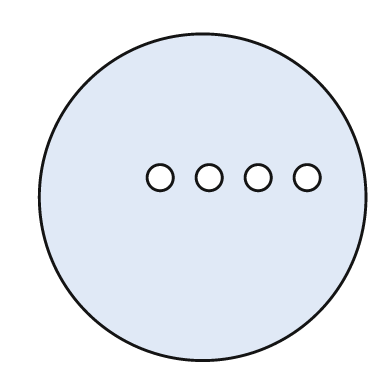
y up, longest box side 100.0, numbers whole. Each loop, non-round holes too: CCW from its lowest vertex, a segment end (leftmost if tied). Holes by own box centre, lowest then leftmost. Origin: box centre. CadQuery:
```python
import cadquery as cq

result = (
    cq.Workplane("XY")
    .moveTo(0.0, 0.0)
    .circle(50.0)
    .moveTo(-13.0, 6.0)
    .circle(4.0)
    .moveTo(2.0, 6.0)
    .circle(4.0)
    .moveTo(17.0, 6.0)
    .circle(4.0)
    .moveTo(32.0, 6.0)
    .circle(4.0)
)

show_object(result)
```